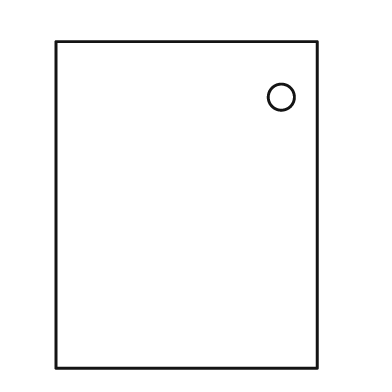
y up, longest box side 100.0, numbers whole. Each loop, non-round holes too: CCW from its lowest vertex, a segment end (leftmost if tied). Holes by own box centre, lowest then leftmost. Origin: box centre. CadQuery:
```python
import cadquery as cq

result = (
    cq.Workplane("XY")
    .moveTo(-40.0, -50.0)
    .lineTo(40.0, -50.0)
    .lineTo(40.0, 50.0)
    .lineTo(-40.0, 50.0)
    .close()
    .moveTo(29.0, 33.0)
    .circle(4.0)
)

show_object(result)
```